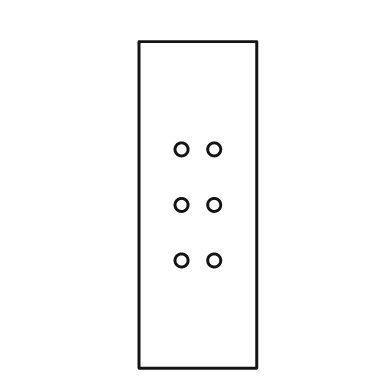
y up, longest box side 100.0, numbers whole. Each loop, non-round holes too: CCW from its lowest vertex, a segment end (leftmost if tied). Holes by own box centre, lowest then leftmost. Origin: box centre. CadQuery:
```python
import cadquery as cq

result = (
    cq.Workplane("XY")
    .moveTo(-18.0, -50.0)
    .lineTo(18.0, -50.0)
    .lineTo(18.0, 50.0)
    .lineTo(-18.0, 50.0)
    .close()
    .moveTo(-5.0, -17.0)
    .circle(2.0)
    .moveTo(5.0, -17.0)
    .circle(2.0)
    .moveTo(-5.0, 0.0)
    .circle(2.0)
    .moveTo(5.0, 0.0)
    .circle(2.0)
    .moveTo(-5.0, 17.0)
    .circle(2.0)
    .moveTo(5.0, 17.0)
    .circle(2.0)
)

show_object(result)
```